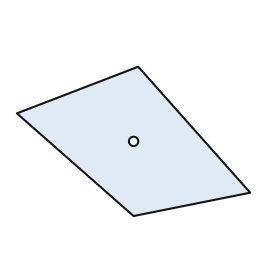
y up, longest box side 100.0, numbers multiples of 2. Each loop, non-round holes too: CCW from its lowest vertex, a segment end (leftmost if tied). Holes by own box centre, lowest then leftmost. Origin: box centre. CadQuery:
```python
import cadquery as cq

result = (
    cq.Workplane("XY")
    .moveTo(0.0, -32.0)
    .lineTo(50.0, -22.0)
    .lineTo(2.0, 32.0)
    .lineTo(-50.0, 12.0)
    .close()
    .moveTo(0.0, 0.0)
    .circle(2.0)
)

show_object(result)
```